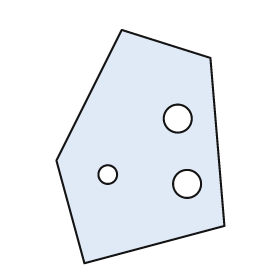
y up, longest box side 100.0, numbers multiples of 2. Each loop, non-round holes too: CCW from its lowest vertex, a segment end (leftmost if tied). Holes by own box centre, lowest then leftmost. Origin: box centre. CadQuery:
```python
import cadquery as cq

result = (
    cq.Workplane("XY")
    .moveTo(-24.0, -50.0)
    .lineTo(36.0, -34.0)
    .lineTo(30.0, 38.0)
    .lineTo(-8.0, 50.0)
    .lineTo(-36.0, -6.0)
    .close()
    .moveTo(20.0, -16.0)
    .circle(6.0)
    .moveTo(-14.0, -12.0)
    .circle(4.0)
    .moveTo(16.0, 12.0)
    .circle(6.0)
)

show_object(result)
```